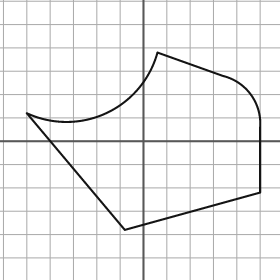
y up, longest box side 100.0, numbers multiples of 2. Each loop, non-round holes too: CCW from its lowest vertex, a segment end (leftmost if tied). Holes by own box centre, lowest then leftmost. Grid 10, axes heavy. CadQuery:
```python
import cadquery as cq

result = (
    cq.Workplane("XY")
    .moveTo(-8.0, -38.0)
    .lineTo(50.0, -22.0)
    .lineTo(50.0, 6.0)
    .threePointArc((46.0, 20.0), (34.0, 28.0))
    .lineTo(6.0, 38.0)
    .threePointArc((-16.0, 12.0), (-50.0, 12.0))
    .close()
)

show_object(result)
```